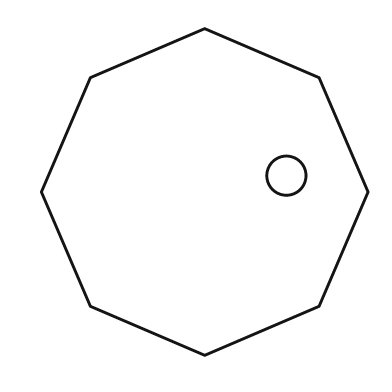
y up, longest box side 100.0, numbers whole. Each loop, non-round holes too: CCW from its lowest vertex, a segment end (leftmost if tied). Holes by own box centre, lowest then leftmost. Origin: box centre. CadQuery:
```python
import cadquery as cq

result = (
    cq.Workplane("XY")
    .moveTo(0.0, -50.0)
    .lineTo(35.0, -35.0)
    .lineTo(50.0, 0.0)
    .lineTo(35.0, 35.0)
    .lineTo(0.0, 50.0)
    .lineTo(-35.0, 35.0)
    .lineTo(-50.0, 0.0)
    .lineTo(-35.0, -35.0)
    .close()
    .moveTo(25.0, 5.0)
    .circle(6.0)
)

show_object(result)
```